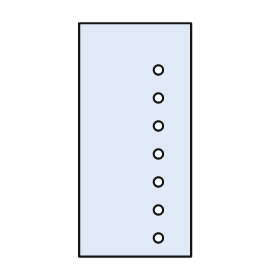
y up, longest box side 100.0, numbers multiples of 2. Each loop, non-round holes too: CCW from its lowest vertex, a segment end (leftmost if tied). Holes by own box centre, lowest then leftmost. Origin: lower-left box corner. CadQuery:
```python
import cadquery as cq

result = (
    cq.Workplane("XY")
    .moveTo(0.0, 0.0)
    .lineTo(48.0, 0.0)
    .lineTo(48.0, 100.0)
    .lineTo(0.0, 100.0)
    .close()
    .moveTo(34.0, 8.0)
    .circle(2.0)
    .moveTo(34.0, 20.0)
    .circle(2.0)
    .moveTo(34.0, 32.0)
    .circle(2.0)
    .moveTo(34.0, 44.0)
    .circle(2.0)
    .moveTo(34.0, 56.0)
    .circle(2.0)
    .moveTo(34.0, 68.0)
    .circle(2.0)
    .moveTo(34.0, 80.0)
    .circle(2.0)
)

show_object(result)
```